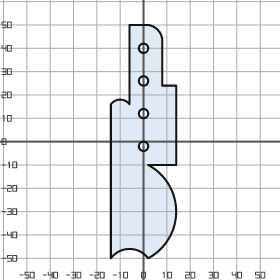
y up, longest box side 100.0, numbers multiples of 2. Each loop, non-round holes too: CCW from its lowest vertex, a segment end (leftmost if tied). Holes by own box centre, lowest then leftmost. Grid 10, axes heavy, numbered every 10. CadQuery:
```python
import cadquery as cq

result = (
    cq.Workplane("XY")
    .moveTo(-14.0, -50.0)
    .threePointArc((-6.0, -46.0), (2.0, -50.0))
    .threePointArc((14.0, -30.0), (2.0, -10.0))
    .lineTo(14.0, -10.0)
    .lineTo(14.0, 24.0)
    .lineTo(8.0, 24.0)
    .lineTo(8.0, 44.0)
    .threePointArc((6.0, 48.0), (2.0, 50.0))
    .lineTo(-6.0, 50.0)
    .lineTo(-6.0, 16.0)
    .threePointArc((-10.0, 18.0), (-14.0, 16.0))
    .close()
    .moveTo(0.0, -2.0)
    .circle(2.0)
    .moveTo(0.0, 12.0)
    .circle(2.0)
    .moveTo(0.0, 26.0)
    .circle(2.0)
    .moveTo(0.0, 40.0)
    .circle(2.0)
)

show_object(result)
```